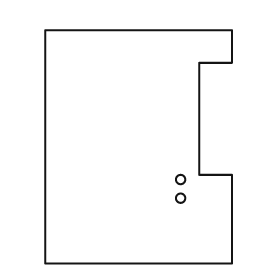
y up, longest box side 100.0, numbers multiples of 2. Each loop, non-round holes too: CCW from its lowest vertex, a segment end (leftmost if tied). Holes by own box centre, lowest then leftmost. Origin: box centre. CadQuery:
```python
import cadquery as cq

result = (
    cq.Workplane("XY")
    .moveTo(-40.0, -50.0)
    .lineTo(40.0, -50.0)
    .lineTo(40.0, -12.0)
    .lineTo(26.0, -12.0)
    .lineTo(26.0, 36.0)
    .lineTo(40.0, 36.0)
    .lineTo(40.0, 50.0)
    .lineTo(-40.0, 50.0)
    .close()
    .moveTo(18.0, -22.0)
    .circle(2.0)
    .moveTo(18.0, -14.0)
    .circle(2.0)
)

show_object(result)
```